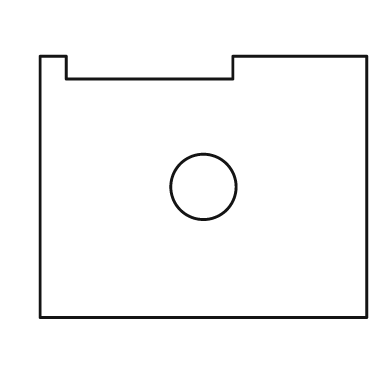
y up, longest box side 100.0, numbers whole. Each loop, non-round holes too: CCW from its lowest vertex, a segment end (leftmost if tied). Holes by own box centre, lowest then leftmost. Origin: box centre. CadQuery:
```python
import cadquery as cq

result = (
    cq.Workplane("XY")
    .moveTo(-50.0, -40.0)
    .lineTo(50.0, -40.0)
    .lineTo(50.0, 40.0)
    .lineTo(9.0, 40.0)
    .lineTo(9.0, 33.0)
    .lineTo(-42.0, 33.0)
    .lineTo(-42.0, 40.0)
    .lineTo(-50.0, 40.0)
    .close()
    .moveTo(0.0, 0.0)
    .circle(10.0)
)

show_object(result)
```